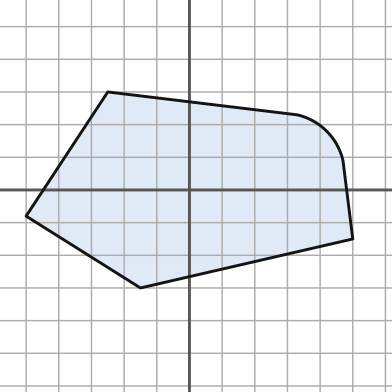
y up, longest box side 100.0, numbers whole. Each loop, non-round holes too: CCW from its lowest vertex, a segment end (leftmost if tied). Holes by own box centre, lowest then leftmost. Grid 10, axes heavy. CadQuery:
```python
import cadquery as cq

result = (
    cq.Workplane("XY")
    .moveTo(-15.0, -30.0)
    .lineTo(50.0, -15.0)
    .lineTo(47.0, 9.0)
    .threePointArc((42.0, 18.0), (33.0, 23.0))
    .lineTo(-25.0, 30.0)
    .lineTo(-50.0, -8.0)
    .close()
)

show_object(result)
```